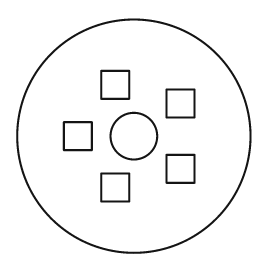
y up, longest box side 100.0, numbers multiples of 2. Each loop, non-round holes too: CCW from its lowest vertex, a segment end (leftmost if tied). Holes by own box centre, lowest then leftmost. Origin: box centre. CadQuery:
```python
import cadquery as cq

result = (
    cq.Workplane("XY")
    .moveTo(0.0, 0.0)
    .circle(50.0)
    .moveTo(-14.0, -28.0)
    .lineTo(-2.0, -28.0)
    .lineTo(-2.0, -16.0)
    .lineTo(-14.0, -16.0)
    .close()
    .moveTo(14.0, -20.0)
    .lineTo(26.0, -20.0)
    .lineTo(26.0, -8.0)
    .lineTo(14.0, -8.0)
    .close()
    .moveTo(-30.0, -6.0)
    .lineTo(-18.0, -6.0)
    .lineTo(-18.0, 6.0)
    .lineTo(-30.0, 6.0)
    .close()
    .moveTo(0.0, 0.0)
    .circle(10.0)
    .moveTo(14.0, 8.0)
    .lineTo(26.0, 8.0)
    .lineTo(26.0, 20.0)
    .lineTo(14.0, 20.0)
    .close()
    .moveTo(-14.0, 16.0)
    .lineTo(-2.0, 16.0)
    .lineTo(-2.0, 28.0)
    .lineTo(-14.0, 28.0)
    .close()
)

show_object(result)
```